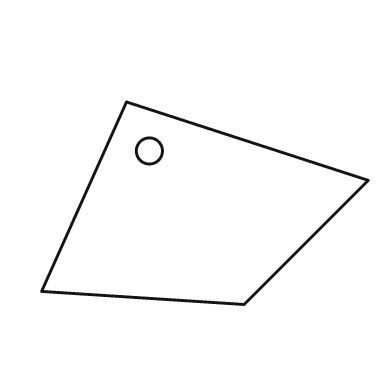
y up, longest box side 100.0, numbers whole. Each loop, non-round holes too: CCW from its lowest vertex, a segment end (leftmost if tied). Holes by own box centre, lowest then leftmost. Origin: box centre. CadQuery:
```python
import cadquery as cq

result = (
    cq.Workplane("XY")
    .moveTo(12.0, -31.0)
    .lineTo(50.0, 7.0)
    .lineTo(-24.0, 31.0)
    .lineTo(-50.0, -27.0)
    .close()
    .moveTo(-17.0, 16.0)
    .circle(4.0)
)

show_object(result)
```